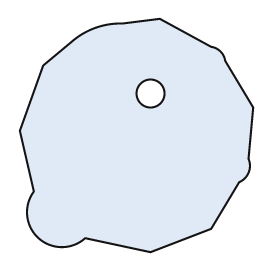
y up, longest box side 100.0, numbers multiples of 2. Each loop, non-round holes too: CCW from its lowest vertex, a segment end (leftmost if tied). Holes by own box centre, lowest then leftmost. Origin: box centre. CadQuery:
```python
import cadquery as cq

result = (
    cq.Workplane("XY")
    .moveTo(6.0, -50.0)
    .lineTo(32.0, -40.0)
    .lineTo(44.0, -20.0)
    .threePointArc((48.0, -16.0), (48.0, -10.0))
    .lineTo(50.0, 12.0)
    .lineTo(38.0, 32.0)
    .threePointArc((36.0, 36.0), (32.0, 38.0))
    .lineTo(10.0, 50.0)
    .lineTo(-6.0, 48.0)
    .threePointArc((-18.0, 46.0), (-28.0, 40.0))
    .lineTo(-40.0, 30.0)
    .lineTo(-50.0, 2.0)
    .lineTo(-44.0, -24.0)
    .threePointArc((-42.0, -44.0), (-22.0, -44.0))
    .close()
    .moveTo(6.0, 18.0)
    .circle(6.0)
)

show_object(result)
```